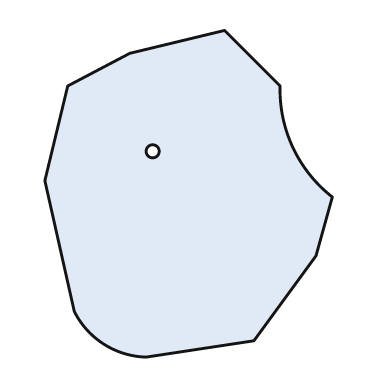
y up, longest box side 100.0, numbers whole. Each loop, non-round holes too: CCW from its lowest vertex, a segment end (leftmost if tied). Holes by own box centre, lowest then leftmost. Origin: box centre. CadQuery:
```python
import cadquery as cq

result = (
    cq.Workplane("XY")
    .moveTo(-13.0, -50.0)
    .lineTo(20.0, -45.0)
    .lineTo(39.0, -19.0)
    .lineTo(44.0, -1.0)
    .threePointArc((32.0, 14.0), (28.0, 33.0))
    .lineTo(11.0, 50.0)
    .lineTo(-18.0, 43.0)
    .lineTo(-37.0, 33.0)
    .lineTo(-44.0, 4.0)
    .lineTo(-35.0, -36.0)
    .threePointArc((-26.0, -46.0), (-13.0, -50.0))
    .close()
    .moveTo(-11.0, 13.0)
    .circle(2.0)
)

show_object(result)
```